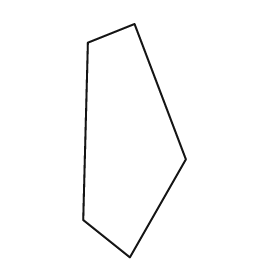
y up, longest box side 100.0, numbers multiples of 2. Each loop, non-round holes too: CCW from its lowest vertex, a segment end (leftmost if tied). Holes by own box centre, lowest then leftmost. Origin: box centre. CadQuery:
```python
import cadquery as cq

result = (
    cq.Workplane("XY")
    .moveTo(-2.0, -50.0)
    .lineTo(22.0, -8.0)
    .lineTo(0.0, 50.0)
    .lineTo(-20.0, 42.0)
    .lineTo(-22.0, -34.0)
    .close()
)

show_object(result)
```